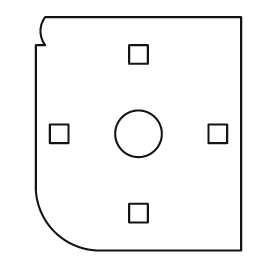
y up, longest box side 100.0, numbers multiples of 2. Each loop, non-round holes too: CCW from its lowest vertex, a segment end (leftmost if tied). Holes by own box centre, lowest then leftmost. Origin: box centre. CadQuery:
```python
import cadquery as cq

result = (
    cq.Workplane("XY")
    .moveTo(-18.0, -50.0)
    .lineTo(44.0, -50.0)
    .lineTo(44.0, 50.0)
    .lineTo(-40.0, 50.0)
    .threePointArc((-42.0, 44.0), (-40.0, 38.0))
    .lineTo(-44.0, 38.0)
    .lineTo(-44.0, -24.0)
    .threePointArc((-36.0, -42.0), (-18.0, -50.0))
    .close()
    .moveTo(-4.0, -38.0)
    .lineTo(4.0, -38.0)
    .lineTo(4.0, -30.0)
    .lineTo(-4.0, -30.0)
    .close()
    .moveTo(-38.0, -4.0)
    .lineTo(-30.0, -4.0)
    .lineTo(-30.0, 4.0)
    .lineTo(-38.0, 4.0)
    .close()
    .moveTo(0.0, 0.0)
    .circle(10.0)
    .moveTo(30.0, -4.0)
    .lineTo(38.0, -4.0)
    .lineTo(38.0, 4.0)
    .lineTo(30.0, 4.0)
    .close()
    .moveTo(-4.0, 30.0)
    .lineTo(4.0, 30.0)
    .lineTo(4.0, 38.0)
    .lineTo(-4.0, 38.0)
    .close()
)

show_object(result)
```